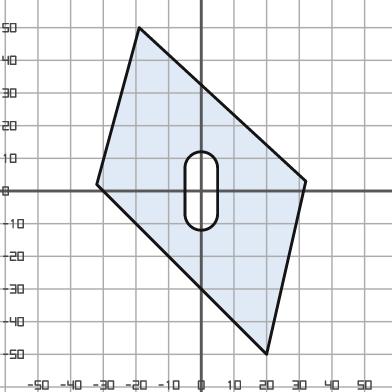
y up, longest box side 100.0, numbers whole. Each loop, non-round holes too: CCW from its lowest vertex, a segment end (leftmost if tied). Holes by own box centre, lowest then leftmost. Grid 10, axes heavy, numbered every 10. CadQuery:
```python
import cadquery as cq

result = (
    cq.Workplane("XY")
    .moveTo(20.0, -50.0)
    .lineTo(32.0, 3.0)
    .lineTo(-19.0, 50.0)
    .lineTo(-32.0, 2.0)
    .close()
    .moveTo(-5.0, -7.0)
    .threePointArc((0.0, -12.0), (5.0, -7.0))
    .lineTo(5.0, 7.0)
    .threePointArc((0.0, 12.0), (-5.0, 7.0))
    .close()
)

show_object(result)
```